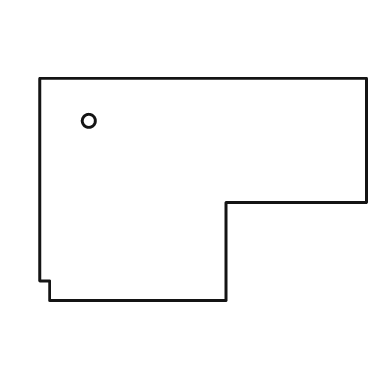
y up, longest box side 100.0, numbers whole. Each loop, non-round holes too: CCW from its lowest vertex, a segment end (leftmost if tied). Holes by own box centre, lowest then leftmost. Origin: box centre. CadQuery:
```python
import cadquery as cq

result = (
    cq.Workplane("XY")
    .moveTo(-47.0, -34.0)
    .lineTo(7.0, -34.0)
    .lineTo(7.0, -4.0)
    .lineTo(50.0, -4.0)
    .lineTo(50.0, 34.0)
    .lineTo(-50.0, 34.0)
    .lineTo(-50.0, -28.0)
    .lineTo(-47.0, -28.0)
    .close()
    .moveTo(-35.0, 21.0)
    .circle(2.0)
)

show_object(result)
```